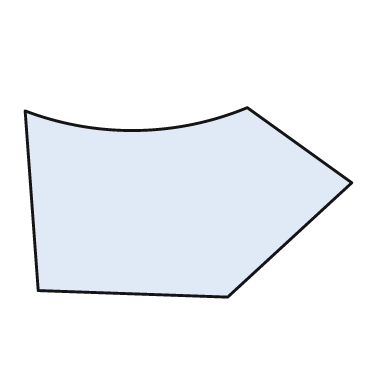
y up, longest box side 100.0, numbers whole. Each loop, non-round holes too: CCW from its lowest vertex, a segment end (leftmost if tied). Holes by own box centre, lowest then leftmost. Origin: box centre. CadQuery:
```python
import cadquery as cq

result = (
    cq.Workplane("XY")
    .moveTo(12.0, -29.0)
    .lineTo(50.0, 6.0)
    .lineTo(18.0, 29.0)
    .threePointArc((-16.0, 22.0), (-50.0, 28.0))
    .lineTo(-46.0, -27.0)
    .close()
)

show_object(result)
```